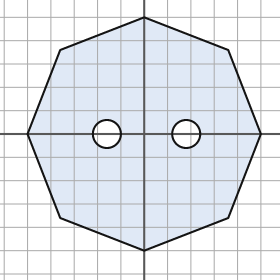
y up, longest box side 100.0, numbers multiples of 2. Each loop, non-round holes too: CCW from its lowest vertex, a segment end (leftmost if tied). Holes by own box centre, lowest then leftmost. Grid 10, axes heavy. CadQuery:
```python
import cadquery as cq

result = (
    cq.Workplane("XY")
    .moveTo(0.0, -50.0)
    .lineTo(36.0, -36.0)
    .lineTo(50.0, 0.0)
    .lineTo(36.0, 36.0)
    .lineTo(0.0, 50.0)
    .lineTo(-36.0, 36.0)
    .lineTo(-50.0, 0.0)
    .lineTo(-36.0, -36.0)
    .close()
    .moveTo(-16.0, 0.0)
    .circle(6.0)
    .moveTo(18.0, 0.0)
    .circle(6.0)
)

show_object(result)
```